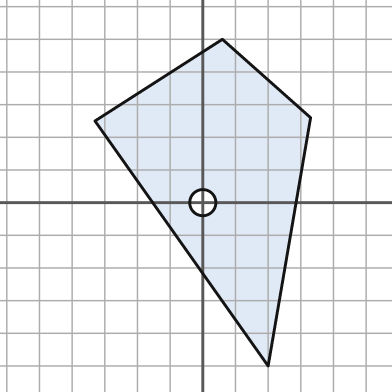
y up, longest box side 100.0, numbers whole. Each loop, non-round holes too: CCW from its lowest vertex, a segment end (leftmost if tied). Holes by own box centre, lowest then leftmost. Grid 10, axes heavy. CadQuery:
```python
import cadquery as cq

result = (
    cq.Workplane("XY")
    .moveTo(20.0, -50.0)
    .lineTo(33.0, 26.0)
    .lineTo(6.0, 50.0)
    .lineTo(-33.0, 25.0)
    .close()
    .moveTo(0.0, 0.0)
    .circle(4.0)
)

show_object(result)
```